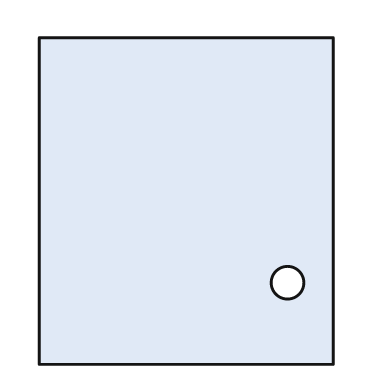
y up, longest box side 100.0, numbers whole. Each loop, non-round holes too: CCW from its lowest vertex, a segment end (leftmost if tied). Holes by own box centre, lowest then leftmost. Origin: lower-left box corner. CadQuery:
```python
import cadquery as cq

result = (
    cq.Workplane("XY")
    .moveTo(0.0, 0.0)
    .lineTo(90.0, 0.0)
    .lineTo(90.0, 100.0)
    .lineTo(0.0, 100.0)
    .close()
    .moveTo(76.0, 25.0)
    .circle(5.0)
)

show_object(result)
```